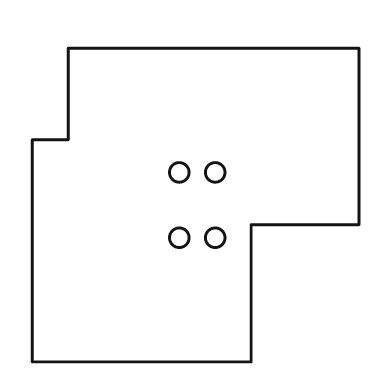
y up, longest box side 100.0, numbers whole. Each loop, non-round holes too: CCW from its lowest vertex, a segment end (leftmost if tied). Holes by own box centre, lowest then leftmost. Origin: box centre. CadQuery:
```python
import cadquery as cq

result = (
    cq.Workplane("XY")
    .moveTo(-50.0, -48.0)
    .lineTo(17.0, -48.0)
    .lineTo(17.0, -6.0)
    .lineTo(50.0, -6.0)
    .lineTo(50.0, 48.0)
    .lineTo(-39.0, 48.0)
    .lineTo(-39.0, 20.0)
    .lineTo(-50.0, 20.0)
    .close()
    .moveTo(-5.0, -10.0)
    .circle(3.0)
    .moveTo(6.0, -10.0)
    .circle(3.0)
    .moveTo(-5.0, 10.0)
    .circle(3.0)
    .moveTo(6.0, 10.0)
    .circle(3.0)
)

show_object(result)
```